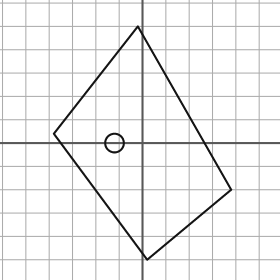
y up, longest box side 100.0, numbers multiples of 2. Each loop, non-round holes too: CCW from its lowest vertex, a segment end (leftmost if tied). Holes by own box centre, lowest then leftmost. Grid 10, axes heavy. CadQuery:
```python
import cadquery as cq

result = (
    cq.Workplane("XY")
    .moveTo(2.0, -50.0)
    .lineTo(38.0, -20.0)
    .lineTo(-2.0, 50.0)
    .lineTo(-38.0, 4.0)
    .close()
    .moveTo(-12.0, 0.0)
    .circle(4.0)
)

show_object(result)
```